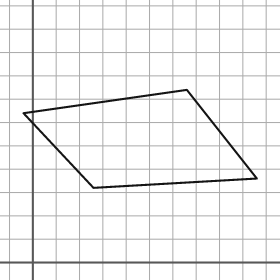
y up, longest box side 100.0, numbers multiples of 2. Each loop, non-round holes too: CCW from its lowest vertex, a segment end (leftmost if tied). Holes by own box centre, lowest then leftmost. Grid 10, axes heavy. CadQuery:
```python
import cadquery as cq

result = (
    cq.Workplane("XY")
    .moveTo(26.0, 32.0)
    .lineTo(96.0, 36.0)
    .lineTo(66.0, 74.0)
    .lineTo(-4.0, 64.0)
    .close()
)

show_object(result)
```